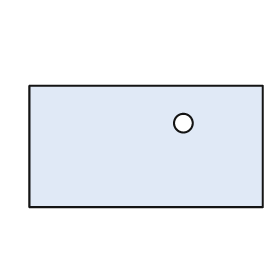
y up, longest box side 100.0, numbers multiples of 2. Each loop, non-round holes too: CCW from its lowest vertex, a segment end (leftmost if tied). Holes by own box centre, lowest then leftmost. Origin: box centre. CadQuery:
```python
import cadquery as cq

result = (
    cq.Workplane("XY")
    .moveTo(-50.0, -26.0)
    .lineTo(50.0, -26.0)
    .lineTo(50.0, 26.0)
    .lineTo(-50.0, 26.0)
    .close()
    .moveTo(16.0, 10.0)
    .circle(4.0)
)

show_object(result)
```